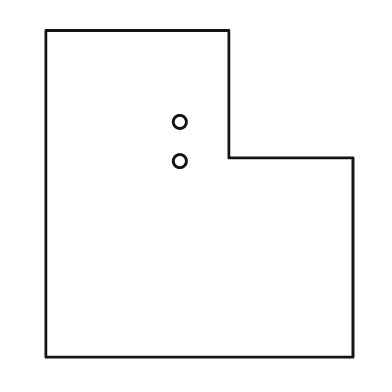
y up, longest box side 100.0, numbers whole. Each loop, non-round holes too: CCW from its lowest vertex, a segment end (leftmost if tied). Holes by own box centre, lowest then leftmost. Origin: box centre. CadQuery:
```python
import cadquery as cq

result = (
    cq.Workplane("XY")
    .moveTo(-47.0, -50.0)
    .lineTo(47.0, -50.0)
    .lineTo(47.0, 11.0)
    .lineTo(9.0, 11.0)
    .lineTo(9.0, 50.0)
    .lineTo(-47.0, 50.0)
    .close()
    .moveTo(-6.0, 10.0)
    .circle(2.0)
    .moveTo(-6.0, 22.0)
    .circle(2.0)
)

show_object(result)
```